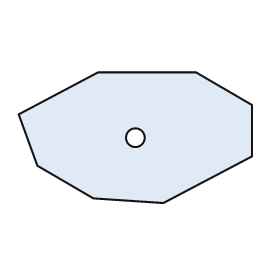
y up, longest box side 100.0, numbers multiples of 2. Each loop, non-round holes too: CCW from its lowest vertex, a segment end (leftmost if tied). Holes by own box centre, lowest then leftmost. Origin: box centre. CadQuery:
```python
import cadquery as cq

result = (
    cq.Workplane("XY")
    .moveTo(12.0, -28.0)
    .lineTo(50.0, -8.0)
    .lineTo(50.0, 14.0)
    .lineTo(26.0, 28.0)
    .lineTo(-16.0, 28.0)
    .lineTo(-50.0, 10.0)
    .lineTo(-42.0, -12.0)
    .lineTo(-18.0, -26.0)
    .close()
    .moveTo(0.0, 0.0)
    .circle(4.0)
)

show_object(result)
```